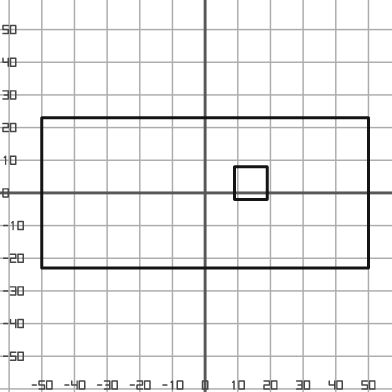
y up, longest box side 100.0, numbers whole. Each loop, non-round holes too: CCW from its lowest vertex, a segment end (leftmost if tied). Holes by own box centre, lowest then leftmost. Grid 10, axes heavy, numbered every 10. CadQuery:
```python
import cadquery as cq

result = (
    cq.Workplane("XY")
    .moveTo(-50.0, -23.0)
    .lineTo(50.0, -23.0)
    .lineTo(50.0, 23.0)
    .lineTo(-50.0, 23.0)
    .close()
    .moveTo(9.0, -2.0)
    .lineTo(19.0, -2.0)
    .lineTo(19.0, 8.0)
    .lineTo(9.0, 8.0)
    .close()
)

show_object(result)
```